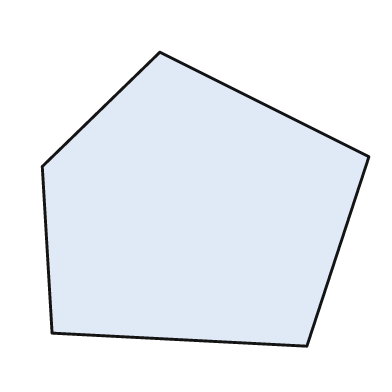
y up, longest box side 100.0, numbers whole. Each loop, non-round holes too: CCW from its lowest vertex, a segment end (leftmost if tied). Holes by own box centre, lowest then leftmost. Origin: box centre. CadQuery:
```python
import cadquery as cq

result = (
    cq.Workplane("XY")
    .moveTo(31.0, -45.0)
    .lineTo(50.0, 13.0)
    .lineTo(-14.0, 45.0)
    .lineTo(-50.0, 10.0)
    .lineTo(-47.0, -41.0)
    .close()
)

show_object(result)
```